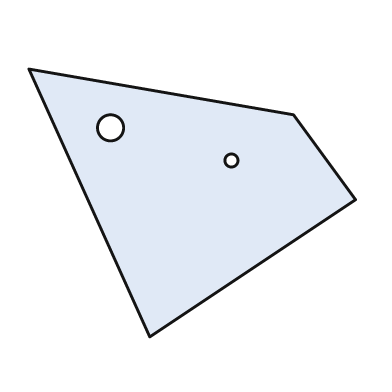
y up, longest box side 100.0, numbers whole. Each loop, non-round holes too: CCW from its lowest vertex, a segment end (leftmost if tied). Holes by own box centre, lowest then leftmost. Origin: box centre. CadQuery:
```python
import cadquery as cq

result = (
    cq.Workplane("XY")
    .moveTo(-13.0, -41.0)
    .lineTo(50.0, 1.0)
    .lineTo(31.0, 27.0)
    .lineTo(-50.0, 41.0)
    .close()
    .moveTo(12.0, 13.0)
    .circle(2.0)
    .moveTo(-25.0, 23.0)
    .circle(4.0)
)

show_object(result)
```